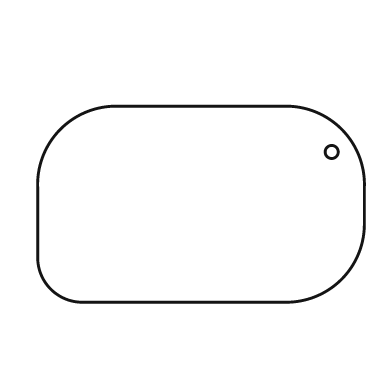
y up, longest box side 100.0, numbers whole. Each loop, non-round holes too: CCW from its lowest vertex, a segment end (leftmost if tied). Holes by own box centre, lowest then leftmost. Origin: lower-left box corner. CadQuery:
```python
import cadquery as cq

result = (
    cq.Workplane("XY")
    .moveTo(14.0, 0.0)
    .lineTo(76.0, 0.0)
    .threePointArc((93.0, 7.0), (100.0, 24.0))
    .lineTo(100.0, 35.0)
    .threePointArc((93.0, 53.0), (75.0, 60.0))
    .lineTo(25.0, 60.0)
    .threePointArc((7.0, 53.0), (0.0, 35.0))
    .lineTo(0.0, 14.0)
    .threePointArc((4.0, 4.0), (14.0, 0.0))
    .close()
    .moveTo(90.0, 46.0)
    .circle(2.0)
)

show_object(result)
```